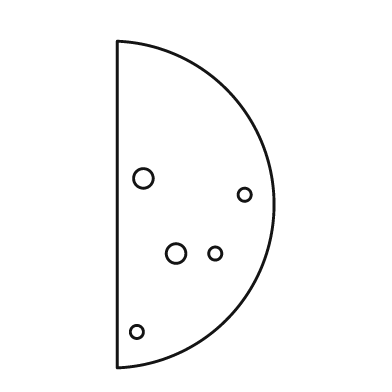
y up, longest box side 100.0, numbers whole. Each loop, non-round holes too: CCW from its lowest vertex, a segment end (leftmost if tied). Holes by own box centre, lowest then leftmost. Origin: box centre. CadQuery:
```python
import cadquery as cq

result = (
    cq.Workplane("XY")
    .moveTo(-24.0, -50.0)
    .threePointArc((24.0, 0.0), (-24.0, 50.0))
    .close()
    .moveTo(-18.0, -39.0)
    .circle(2.0)
    .moveTo(-6.0, -15.0)
    .circle(3.0)
    .moveTo(6.0, -15.0)
    .circle(2.0)
    .moveTo(15.0, 3.0)
    .circle(2.0)
    .moveTo(-16.0, 8.0)
    .circle(3.0)
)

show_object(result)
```